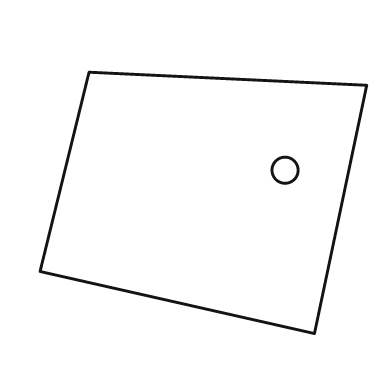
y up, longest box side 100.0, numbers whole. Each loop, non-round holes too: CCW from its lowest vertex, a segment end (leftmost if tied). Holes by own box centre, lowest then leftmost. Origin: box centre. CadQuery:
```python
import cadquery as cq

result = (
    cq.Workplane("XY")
    .moveTo(34.0, -40.0)
    .lineTo(50.0, 36.0)
    .lineTo(-35.0, 40.0)
    .lineTo(-50.0, -21.0)
    .close()
    .moveTo(25.0, 10.0)
    .circle(4.0)
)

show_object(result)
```